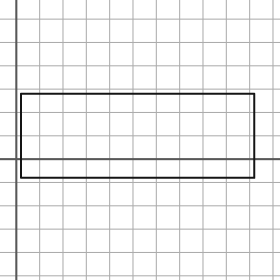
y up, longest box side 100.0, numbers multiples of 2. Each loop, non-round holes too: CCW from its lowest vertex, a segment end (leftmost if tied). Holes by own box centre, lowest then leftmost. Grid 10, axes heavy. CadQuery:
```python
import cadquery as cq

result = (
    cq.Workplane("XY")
    .moveTo(2.0, -8.0)
    .lineTo(102.0, -8.0)
    .lineTo(102.0, 28.0)
    .lineTo(2.0, 28.0)
    .close()
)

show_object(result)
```